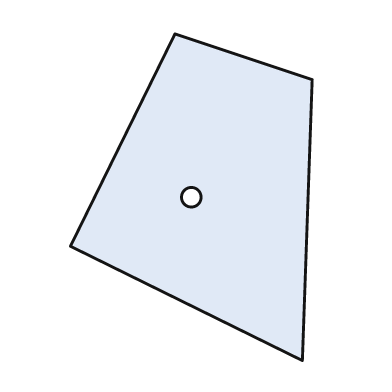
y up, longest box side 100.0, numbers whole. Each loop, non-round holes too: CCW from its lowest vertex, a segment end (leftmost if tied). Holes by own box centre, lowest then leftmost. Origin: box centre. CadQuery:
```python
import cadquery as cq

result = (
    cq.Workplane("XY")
    .moveTo(34.0, -50.0)
    .lineTo(37.0, 36.0)
    .lineTo(-5.0, 50.0)
    .lineTo(-37.0, -15.0)
    .close()
    .moveTo(0.0, 0.0)
    .circle(3.0)
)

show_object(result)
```